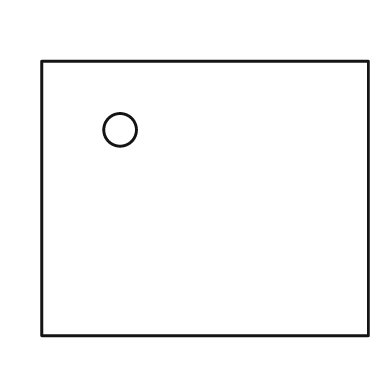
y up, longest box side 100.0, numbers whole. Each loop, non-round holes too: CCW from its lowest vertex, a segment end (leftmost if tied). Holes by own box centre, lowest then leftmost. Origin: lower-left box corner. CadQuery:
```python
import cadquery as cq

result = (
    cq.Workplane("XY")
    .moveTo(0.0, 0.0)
    .lineTo(100.0, 0.0)
    .lineTo(100.0, 84.0)
    .lineTo(0.0, 84.0)
    .close()
    .moveTo(24.0, 63.0)
    .circle(5.0)
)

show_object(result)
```